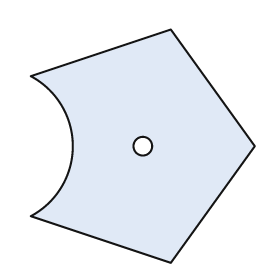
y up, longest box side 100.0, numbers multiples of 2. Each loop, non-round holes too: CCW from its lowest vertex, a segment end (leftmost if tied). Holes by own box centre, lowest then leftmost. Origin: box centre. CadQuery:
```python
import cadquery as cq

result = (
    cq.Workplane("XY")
    .moveTo(12.0, -50.0)
    .lineTo(48.0, 0.0)
    .lineTo(12.0, 50.0)
    .lineTo(-48.0, 30.0)
    .threePointArc((-30.0, 0.0), (-48.0, -30.0))
    .close()
    .moveTo(0.0, 0.0)
    .circle(4.0)
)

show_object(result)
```